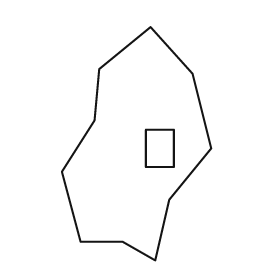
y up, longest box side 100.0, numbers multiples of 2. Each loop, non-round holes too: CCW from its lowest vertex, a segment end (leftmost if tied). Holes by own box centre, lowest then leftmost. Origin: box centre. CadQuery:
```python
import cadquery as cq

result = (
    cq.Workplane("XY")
    .moveTo(8.0, -50.0)
    .lineTo(14.0, -24.0)
    .lineTo(32.0, -2.0)
    .lineTo(24.0, 30.0)
    .lineTo(6.0, 50.0)
    .lineTo(-16.0, 32.0)
    .lineTo(-18.0, 10.0)
    .lineTo(-32.0, -12.0)
    .lineTo(-24.0, -42.0)
    .lineTo(-6.0, -42.0)
    .close()
    .moveTo(4.0, -10.0)
    .lineTo(16.0, -10.0)
    .lineTo(16.0, 6.0)
    .lineTo(4.0, 6.0)
    .close()
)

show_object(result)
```